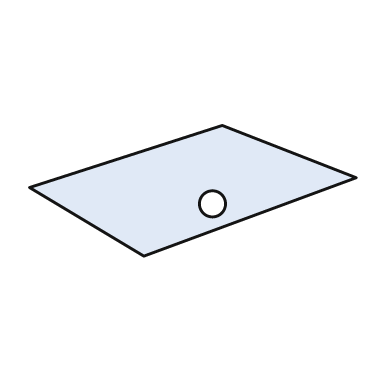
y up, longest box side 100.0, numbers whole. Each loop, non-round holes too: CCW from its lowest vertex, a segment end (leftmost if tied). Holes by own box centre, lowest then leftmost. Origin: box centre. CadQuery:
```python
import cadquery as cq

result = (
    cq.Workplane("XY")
    .moveTo(-15.0, -20.0)
    .lineTo(50.0, 4.0)
    .lineTo(9.0, 20.0)
    .lineTo(-50.0, 1.0)
    .close()
    .moveTo(6.0, -4.0)
    .circle(4.0)
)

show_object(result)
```